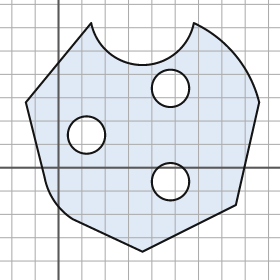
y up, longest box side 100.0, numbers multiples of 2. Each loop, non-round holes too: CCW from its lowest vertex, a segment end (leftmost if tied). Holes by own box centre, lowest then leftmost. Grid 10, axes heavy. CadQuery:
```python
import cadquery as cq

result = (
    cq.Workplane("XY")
    .moveTo(36.0, -36.0)
    .lineTo(76.0, -16.0)
    .lineTo(86.0, 28.0)
    .threePointArc((76.0, 48.0), (58.0, 62.0))
    .threePointArc((36.0, 44.0), (14.0, 62.0))
    .lineTo(-14.0, 28.0)
    .lineTo(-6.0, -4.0)
    .threePointArc((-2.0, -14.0), (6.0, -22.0))
    .close()
    .moveTo(48.0, -6.0)
    .circle(8.0)
    .moveTo(12.0, 14.0)
    .circle(8.0)
    .moveTo(48.0, 34.0)
    .circle(8.0)
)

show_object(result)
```